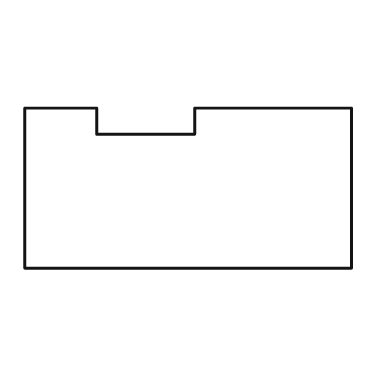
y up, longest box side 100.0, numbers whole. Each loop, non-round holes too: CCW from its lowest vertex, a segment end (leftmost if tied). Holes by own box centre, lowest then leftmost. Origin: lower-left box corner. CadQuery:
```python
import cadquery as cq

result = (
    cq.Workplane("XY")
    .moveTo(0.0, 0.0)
    .lineTo(100.0, 0.0)
    .lineTo(100.0, 49.0)
    .lineTo(52.0, 49.0)
    .lineTo(52.0, 41.0)
    .lineTo(22.0, 41.0)
    .lineTo(22.0, 49.0)
    .lineTo(0.0, 49.0)
    .close()
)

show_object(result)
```